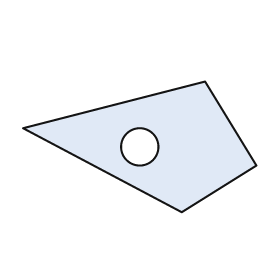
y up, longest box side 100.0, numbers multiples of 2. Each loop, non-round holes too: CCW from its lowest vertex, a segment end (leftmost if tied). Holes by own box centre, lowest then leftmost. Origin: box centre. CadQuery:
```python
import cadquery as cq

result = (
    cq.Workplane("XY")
    .moveTo(18.0, -28.0)
    .lineTo(50.0, -8.0)
    .lineTo(28.0, 28.0)
    .lineTo(-50.0, 8.0)
    .close()
    .moveTo(0.0, 0.0)
    .circle(8.0)
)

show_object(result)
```